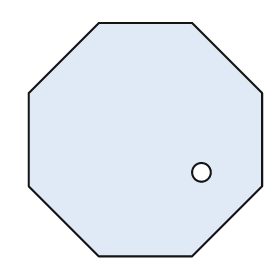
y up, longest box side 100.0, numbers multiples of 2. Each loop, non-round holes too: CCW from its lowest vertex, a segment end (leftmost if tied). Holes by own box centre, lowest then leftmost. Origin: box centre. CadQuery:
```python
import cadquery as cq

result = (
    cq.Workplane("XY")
    .moveTo(-20.0, -50.0)
    .lineTo(20.0, -50.0)
    .lineTo(50.0, -20.0)
    .lineTo(50.0, 20.0)
    .lineTo(20.0, 50.0)
    .lineTo(-20.0, 50.0)
    .lineTo(-50.0, 20.0)
    .lineTo(-50.0, -20.0)
    .close()
    .moveTo(24.0, -14.0)
    .circle(4.0)
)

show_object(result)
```